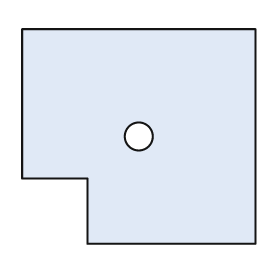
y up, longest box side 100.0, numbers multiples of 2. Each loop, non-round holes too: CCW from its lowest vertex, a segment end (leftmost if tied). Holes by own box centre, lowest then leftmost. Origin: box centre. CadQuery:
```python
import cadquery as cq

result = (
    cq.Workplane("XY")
    .moveTo(-22.0, -46.0)
    .lineTo(50.0, -46.0)
    .lineTo(50.0, 46.0)
    .lineTo(-50.0, 46.0)
    .lineTo(-50.0, -18.0)
    .lineTo(-22.0, -18.0)
    .close()
    .moveTo(0.0, 0.0)
    .circle(6.0)
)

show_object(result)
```